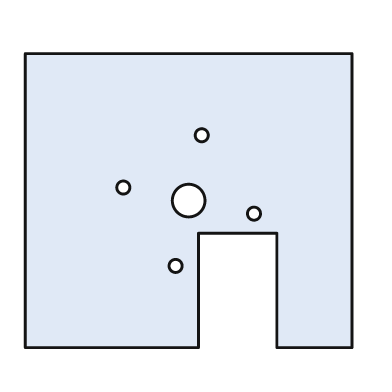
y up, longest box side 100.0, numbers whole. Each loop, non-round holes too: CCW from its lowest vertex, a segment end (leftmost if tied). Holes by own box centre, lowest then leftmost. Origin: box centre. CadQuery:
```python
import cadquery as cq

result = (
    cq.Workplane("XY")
    .moveTo(-50.0, -45.0)
    .lineTo(3.0, -45.0)
    .lineTo(3.0, -10.0)
    .lineTo(27.0, -10.0)
    .lineTo(27.0, -45.0)
    .lineTo(50.0, -45.0)
    .lineTo(50.0, 45.0)
    .lineTo(-50.0, 45.0)
    .close()
    .moveTo(-4.0, -20.0)
    .circle(2.0)
    .moveTo(20.0, -4.0)
    .circle(2.0)
    .moveTo(0.0, 0.0)
    .circle(5.0)
    .moveTo(-20.0, 4.0)
    .circle(2.0)
    .moveTo(4.0, 20.0)
    .circle(2.0)
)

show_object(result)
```